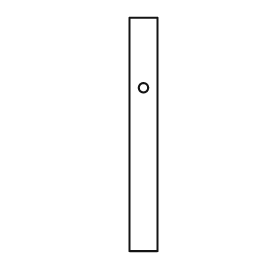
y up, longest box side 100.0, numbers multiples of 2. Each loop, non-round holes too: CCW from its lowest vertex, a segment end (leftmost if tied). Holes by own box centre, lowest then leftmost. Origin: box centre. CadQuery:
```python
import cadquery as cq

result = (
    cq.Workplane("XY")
    .moveTo(-6.0, -50.0)
    .lineTo(6.0, -50.0)
    .lineTo(6.0, 50.0)
    .lineTo(-6.0, 50.0)
    .close()
    .moveTo(0.0, 20.0)
    .circle(2.0)
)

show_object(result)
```